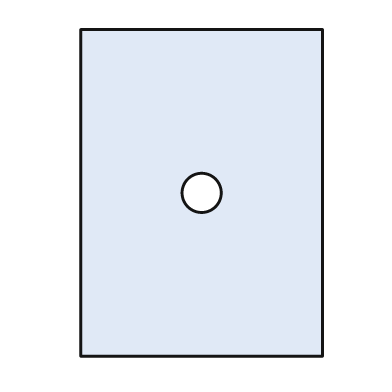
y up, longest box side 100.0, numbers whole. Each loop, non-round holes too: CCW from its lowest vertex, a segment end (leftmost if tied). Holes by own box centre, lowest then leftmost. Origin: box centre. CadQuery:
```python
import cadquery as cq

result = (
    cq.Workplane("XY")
    .moveTo(-37.0, -50.0)
    .lineTo(37.0, -50.0)
    .lineTo(37.0, 50.0)
    .lineTo(-37.0, 50.0)
    .close()
    .moveTo(0.0, 0.0)
    .circle(6.0)
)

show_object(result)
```